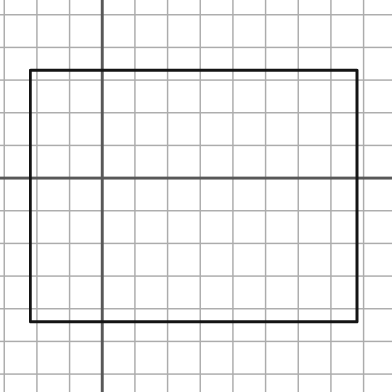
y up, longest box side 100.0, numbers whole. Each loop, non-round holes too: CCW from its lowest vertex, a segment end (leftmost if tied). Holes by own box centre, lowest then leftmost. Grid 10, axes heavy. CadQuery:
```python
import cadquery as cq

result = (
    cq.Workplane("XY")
    .moveTo(-22.0, -44.0)
    .lineTo(78.0, -44.0)
    .lineTo(78.0, 33.0)
    .lineTo(-22.0, 33.0)
    .close()
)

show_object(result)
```